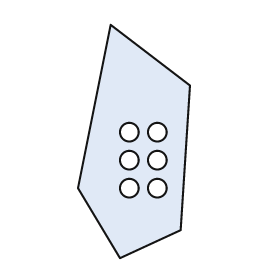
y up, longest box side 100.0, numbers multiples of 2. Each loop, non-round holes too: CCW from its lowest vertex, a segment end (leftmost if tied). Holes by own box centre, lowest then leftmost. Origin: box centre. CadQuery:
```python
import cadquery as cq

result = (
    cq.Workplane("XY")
    .moveTo(-6.0, -50.0)
    .lineTo(20.0, -38.0)
    .lineTo(24.0, 24.0)
    .lineTo(-10.0, 50.0)
    .lineTo(-24.0, -20.0)
    .close()
    .moveTo(-2.0, -20.0)
    .circle(4.0)
    .moveTo(10.0, -20.0)
    .circle(4.0)
    .moveTo(-2.0, -8.0)
    .circle(4.0)
    .moveTo(10.0, -8.0)
    .circle(4.0)
    .moveTo(-2.0, 4.0)
    .circle(4.0)
    .moveTo(10.0, 4.0)
    .circle(4.0)
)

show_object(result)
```